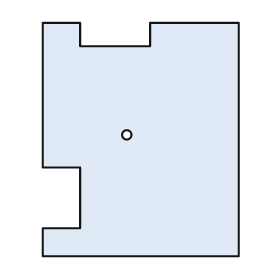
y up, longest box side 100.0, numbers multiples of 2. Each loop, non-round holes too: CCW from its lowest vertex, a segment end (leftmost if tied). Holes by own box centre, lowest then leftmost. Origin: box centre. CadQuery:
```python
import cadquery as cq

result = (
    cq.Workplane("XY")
    .moveTo(-42.0, -50.0)
    .lineTo(42.0, -50.0)
    .lineTo(42.0, 50.0)
    .lineTo(4.0, 50.0)
    .lineTo(4.0, 40.0)
    .lineTo(-26.0, 40.0)
    .lineTo(-26.0, 50.0)
    .lineTo(-42.0, 50.0)
    .lineTo(-42.0, -12.0)
    .lineTo(-26.0, -12.0)
    .lineTo(-26.0, -38.0)
    .lineTo(-42.0, -38.0)
    .close()
    .moveTo(-6.0, 2.0)
    .circle(2.0)
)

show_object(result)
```